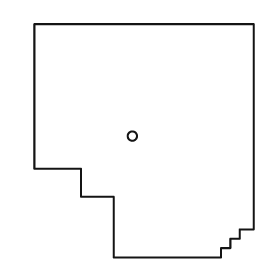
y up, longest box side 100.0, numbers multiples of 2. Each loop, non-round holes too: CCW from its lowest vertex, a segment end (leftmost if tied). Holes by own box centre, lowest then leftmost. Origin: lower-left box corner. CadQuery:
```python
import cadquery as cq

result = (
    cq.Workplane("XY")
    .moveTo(34.0, 0.0)
    .lineTo(80.0, 0.0)
    .lineTo(80.0, 4.0)
    .lineTo(84.0, 4.0)
    .lineTo(84.0, 8.0)
    .lineTo(88.0, 8.0)
    .lineTo(88.0, 12.0)
    .lineTo(94.0, 12.0)
    .lineTo(94.0, 100.0)
    .lineTo(0.0, 100.0)
    .lineTo(0.0, 38.0)
    .lineTo(20.0, 38.0)
    .lineTo(20.0, 26.0)
    .lineTo(34.0, 26.0)
    .close()
    .moveTo(42.0, 52.0)
    .circle(2.0)
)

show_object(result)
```